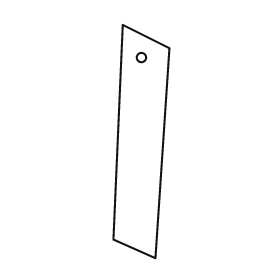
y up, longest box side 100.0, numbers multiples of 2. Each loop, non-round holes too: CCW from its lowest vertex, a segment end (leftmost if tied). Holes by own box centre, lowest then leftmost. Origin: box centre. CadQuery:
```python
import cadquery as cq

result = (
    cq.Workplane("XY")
    .moveTo(6.0, -50.0)
    .lineTo(12.0, 40.0)
    .lineTo(-8.0, 50.0)
    .lineTo(-12.0, -42.0)
    .close()
    .moveTo(0.0, 36.0)
    .circle(2.0)
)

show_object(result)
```